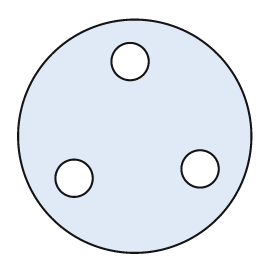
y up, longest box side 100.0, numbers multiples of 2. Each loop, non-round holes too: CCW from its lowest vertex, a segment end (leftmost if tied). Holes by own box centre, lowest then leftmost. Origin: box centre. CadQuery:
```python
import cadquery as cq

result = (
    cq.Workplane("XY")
    .moveTo(0.0, 0.0)
    .circle(50.0)
    .moveTo(-26.0, -18.0)
    .circle(8.0)
    .moveTo(28.0, -14.0)
    .circle(8.0)
    .moveTo(-2.0, 32.0)
    .circle(8.0)
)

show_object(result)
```